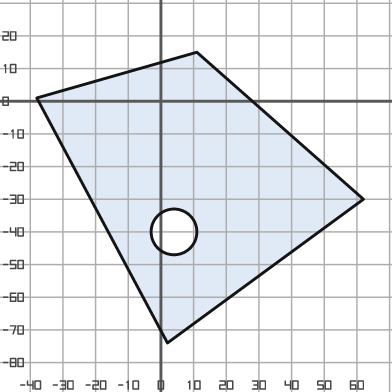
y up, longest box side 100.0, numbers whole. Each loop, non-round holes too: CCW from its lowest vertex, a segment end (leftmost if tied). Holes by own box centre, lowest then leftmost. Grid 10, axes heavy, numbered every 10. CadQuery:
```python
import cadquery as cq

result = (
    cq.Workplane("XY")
    .moveTo(2.0, -74.0)
    .lineTo(62.0, -30.0)
    .lineTo(11.0, 15.0)
    .lineTo(-38.0, 1.0)
    .close()
    .moveTo(4.0, -40.0)
    .circle(7.0)
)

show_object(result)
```